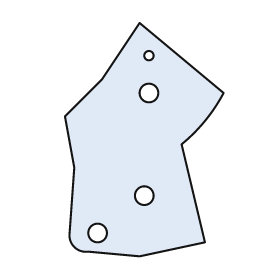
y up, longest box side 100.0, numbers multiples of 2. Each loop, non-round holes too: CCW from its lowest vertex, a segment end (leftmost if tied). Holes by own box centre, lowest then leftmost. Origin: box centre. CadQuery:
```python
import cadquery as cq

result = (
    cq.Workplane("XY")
    .moveTo(-2.0, -50.0)
    .lineTo(26.0, -44.0)
    .lineTo(16.0, -2.0)
    .threePointArc((26.0, 8.0), (34.0, 20.0))
    .lineTo(-2.0, 50.0)
    .lineTo(-18.0, 26.0)
    .lineTo(-34.0, 10.0)
    .lineTo(-30.0, -12.0)
    .lineTo(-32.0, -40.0)
    .threePointArc((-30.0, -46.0), (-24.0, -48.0))
    .close()
    .moveTo(-20.0, -40.0)
    .circle(4.0)
    .moveTo(0.0, -24.0)
    .circle(4.0)
    .moveTo(2.0, 20.0)
    .circle(4.0)
    .moveTo(2.0, 36.0)
    .circle(2.0)
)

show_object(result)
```